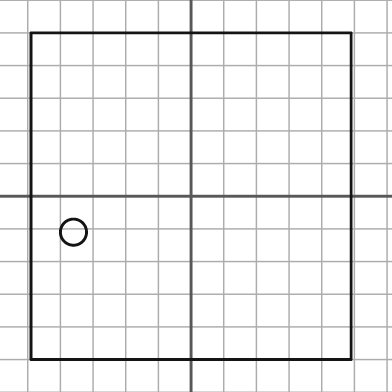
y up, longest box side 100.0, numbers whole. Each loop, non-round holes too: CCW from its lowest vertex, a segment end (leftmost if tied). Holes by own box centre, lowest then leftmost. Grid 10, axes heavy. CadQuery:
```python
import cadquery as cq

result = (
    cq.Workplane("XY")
    .moveTo(-49.0, -50.0)
    .lineTo(49.0, -50.0)
    .lineTo(49.0, 50.0)
    .lineTo(-49.0, 50.0)
    .close()
    .moveTo(-36.0, -11.0)
    .circle(4.0)
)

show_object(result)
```